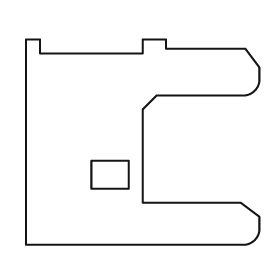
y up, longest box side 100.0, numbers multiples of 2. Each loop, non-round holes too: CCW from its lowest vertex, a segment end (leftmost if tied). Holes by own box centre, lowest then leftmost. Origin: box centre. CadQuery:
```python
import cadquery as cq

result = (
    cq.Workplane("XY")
    .moveTo(-50.0, -44.0)
    .lineTo(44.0, -44.0)
    .threePointArc((48.0, -42.0), (50.0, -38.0))
    .lineTo(50.0, -32.0)
    .lineTo(42.0, -26.0)
    .lineTo(0.0, -26.0)
    .lineTo(0.0, 14.0)
    .lineTo(6.0, 20.0)
    .lineTo(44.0, 20.0)
    .threePointArc((48.0, 22.0), (50.0, 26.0))
    .lineTo(50.0, 32.0)
    .lineTo(44.0, 40.0)
    .lineTo(10.0, 40.0)
    .lineTo(10.0, 44.0)
    .lineTo(0.0, 44.0)
    .lineTo(0.0, 38.0)
    .lineTo(-44.0, 38.0)
    .lineTo(-44.0, 44.0)
    .lineTo(-50.0, 44.0)
    .close()
    .moveTo(-22.0, -20.0)
    .lineTo(-6.0, -20.0)
    .lineTo(-6.0, -8.0)
    .lineTo(-22.0, -8.0)
    .close()
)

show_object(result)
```